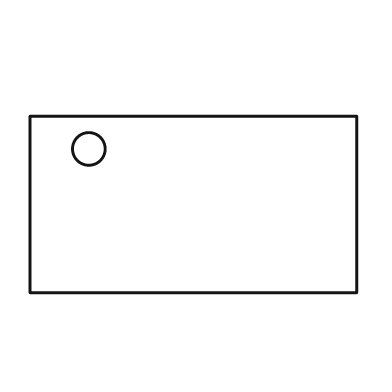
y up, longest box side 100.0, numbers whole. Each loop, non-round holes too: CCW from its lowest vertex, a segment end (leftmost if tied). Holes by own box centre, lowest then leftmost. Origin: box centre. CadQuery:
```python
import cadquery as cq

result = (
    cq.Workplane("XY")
    .moveTo(-50.0, -27.0)
    .lineTo(50.0, -27.0)
    .lineTo(50.0, 27.0)
    .lineTo(-50.0, 27.0)
    .close()
    .moveTo(-32.0, 17.0)
    .circle(5.0)
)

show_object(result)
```